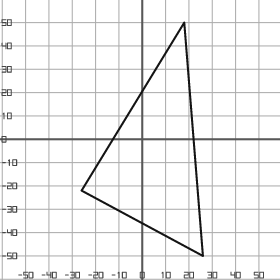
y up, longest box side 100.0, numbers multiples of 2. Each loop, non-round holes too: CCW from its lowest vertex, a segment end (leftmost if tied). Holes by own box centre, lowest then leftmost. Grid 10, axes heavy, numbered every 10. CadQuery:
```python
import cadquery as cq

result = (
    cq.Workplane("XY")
    .moveTo(26.0, -50.0)
    .lineTo(18.0, 50.0)
    .lineTo(-26.0, -22.0)
    .close()
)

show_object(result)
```